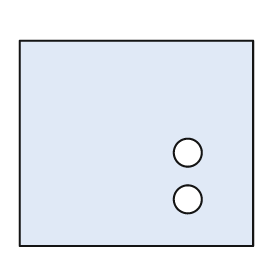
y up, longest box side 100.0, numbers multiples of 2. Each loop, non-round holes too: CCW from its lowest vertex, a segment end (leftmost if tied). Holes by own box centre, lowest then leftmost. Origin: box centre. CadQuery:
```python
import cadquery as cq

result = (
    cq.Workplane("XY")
    .moveTo(-50.0, -44.0)
    .lineTo(50.0, -44.0)
    .lineTo(50.0, 44.0)
    .lineTo(-50.0, 44.0)
    .close()
    .moveTo(22.0, -24.0)
    .circle(6.0)
    .moveTo(22.0, -4.0)
    .circle(6.0)
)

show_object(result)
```